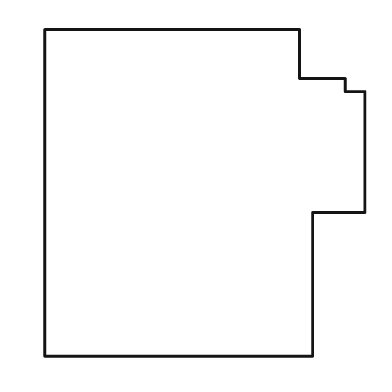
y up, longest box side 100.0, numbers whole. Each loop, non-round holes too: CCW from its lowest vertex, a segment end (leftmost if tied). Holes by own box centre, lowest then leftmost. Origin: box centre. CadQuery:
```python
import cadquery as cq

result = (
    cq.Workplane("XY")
    .moveTo(-49.0, -50.0)
    .lineTo(33.0, -50.0)
    .lineTo(33.0, -6.0)
    .lineTo(49.0, -6.0)
    .lineTo(49.0, 31.0)
    .lineTo(43.0, 31.0)
    .lineTo(43.0, 35.0)
    .lineTo(29.0, 35.0)
    .lineTo(29.0, 50.0)
    .lineTo(-49.0, 50.0)
    .close()
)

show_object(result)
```